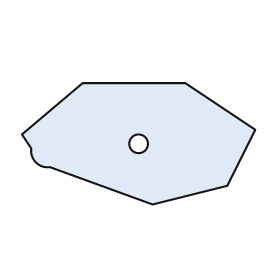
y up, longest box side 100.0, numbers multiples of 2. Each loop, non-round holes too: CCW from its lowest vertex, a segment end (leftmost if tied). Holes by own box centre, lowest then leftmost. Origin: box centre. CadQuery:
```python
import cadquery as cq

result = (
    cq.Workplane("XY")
    .moveTo(6.0, -26.0)
    .lineTo(38.0, -18.0)
    .lineTo(50.0, 6.0)
    .lineTo(20.0, 26.0)
    .lineTo(-24.0, 26.0)
    .lineTo(-50.0, 4.0)
    .lineTo(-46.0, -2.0)
    .threePointArc((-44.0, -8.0), (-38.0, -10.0))
    .close()
    .moveTo(0.0, 0.0)
    .circle(4.0)
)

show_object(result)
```